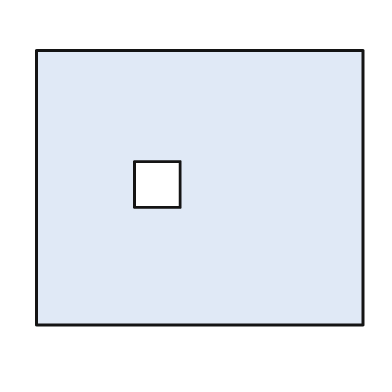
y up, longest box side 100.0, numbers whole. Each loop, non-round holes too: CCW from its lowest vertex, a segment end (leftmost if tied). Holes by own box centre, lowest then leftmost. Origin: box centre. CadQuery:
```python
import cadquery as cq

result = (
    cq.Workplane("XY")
    .moveTo(-50.0, -42.0)
    .lineTo(50.0, -42.0)
    .lineTo(50.0, 42.0)
    .lineTo(-50.0, 42.0)
    .close()
    .moveTo(-20.0, -6.0)
    .lineTo(-6.0, -6.0)
    .lineTo(-6.0, 8.0)
    .lineTo(-20.0, 8.0)
    .close()
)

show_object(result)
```